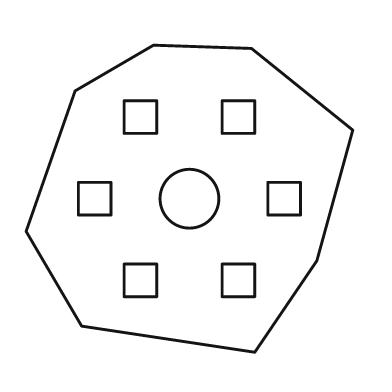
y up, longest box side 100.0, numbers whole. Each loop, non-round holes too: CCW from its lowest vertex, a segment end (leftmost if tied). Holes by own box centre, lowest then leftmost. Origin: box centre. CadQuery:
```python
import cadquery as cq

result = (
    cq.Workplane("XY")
    .moveTo(20.0, -47.0)
    .lineTo(39.0, -19.0)
    .lineTo(50.0, 21.0)
    .lineTo(19.0, 46.0)
    .lineTo(-11.0, 47.0)
    .lineTo(-35.0, 33.0)
    .lineTo(-50.0, -10.0)
    .lineTo(-33.0, -39.0)
    .close()
    .moveTo(-20.0, -30.0)
    .lineTo(-10.0, -30.0)
    .lineTo(-10.0, -20.0)
    .lineTo(-20.0, -20.0)
    .close()
    .moveTo(10.0, -30.0)
    .lineTo(20.0, -30.0)
    .lineTo(20.0, -20.0)
    .lineTo(10.0, -20.0)
    .close()
    .moveTo(-34.0, -5.0)
    .lineTo(-24.0, -5.0)
    .lineTo(-24.0, 5.0)
    .lineTo(-34.0, 5.0)
    .close()
    .moveTo(0.0, 0.0)
    .circle(9.0)
    .moveTo(24.0, -5.0)
    .lineTo(34.0, -5.0)
    .lineTo(34.0, 5.0)
    .lineTo(24.0, 5.0)
    .close()
    .moveTo(-20.0, 20.0)
    .lineTo(-10.0, 20.0)
    .lineTo(-10.0, 30.0)
    .lineTo(-20.0, 30.0)
    .close()
    .moveTo(10.0, 20.0)
    .lineTo(20.0, 20.0)
    .lineTo(20.0, 30.0)
    .lineTo(10.0, 30.0)
    .close()
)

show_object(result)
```